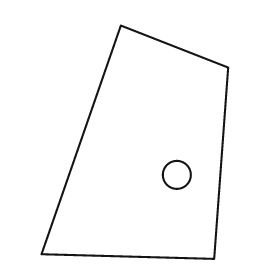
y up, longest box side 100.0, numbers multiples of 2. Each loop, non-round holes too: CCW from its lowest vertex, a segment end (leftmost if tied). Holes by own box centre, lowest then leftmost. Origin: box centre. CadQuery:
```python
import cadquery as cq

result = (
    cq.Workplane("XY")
    .moveTo(34.0, -50.0)
    .lineTo(40.0, 32.0)
    .lineTo(-6.0, 50.0)
    .lineTo(-40.0, -48.0)
    .close()
    .moveTo(18.0, -14.0)
    .circle(6.0)
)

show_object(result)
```